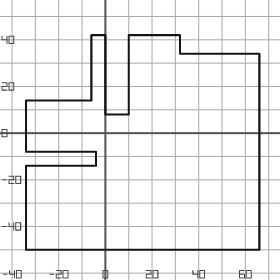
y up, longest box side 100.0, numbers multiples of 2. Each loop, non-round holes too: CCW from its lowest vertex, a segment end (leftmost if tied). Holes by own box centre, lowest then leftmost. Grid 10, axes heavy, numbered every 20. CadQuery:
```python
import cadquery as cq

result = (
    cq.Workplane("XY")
    .moveTo(-34.0, -50.0)
    .lineTo(66.0, -50.0)
    .lineTo(66.0, 34.0)
    .lineTo(32.0, 34.0)
    .lineTo(32.0, 42.0)
    .lineTo(10.0, 42.0)
    .lineTo(10.0, 8.0)
    .lineTo(0.0, 8.0)
    .lineTo(0.0, 42.0)
    .lineTo(-6.0, 42.0)
    .lineTo(-6.0, 14.0)
    .lineTo(-34.0, 14.0)
    .lineTo(-34.0, -8.0)
    .lineTo(-4.0, -8.0)
    .lineTo(-4.0, -14.0)
    .lineTo(-34.0, -14.0)
    .close()
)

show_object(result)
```